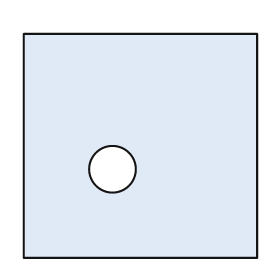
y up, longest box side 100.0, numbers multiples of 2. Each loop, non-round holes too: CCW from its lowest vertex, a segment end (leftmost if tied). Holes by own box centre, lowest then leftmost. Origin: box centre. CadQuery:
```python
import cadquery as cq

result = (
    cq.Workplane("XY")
    .moveTo(-50.0, -48.0)
    .lineTo(50.0, -48.0)
    .lineTo(50.0, 48.0)
    .lineTo(-50.0, 48.0)
    .close()
    .moveTo(-12.0, -10.0)
    .circle(10.0)
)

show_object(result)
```